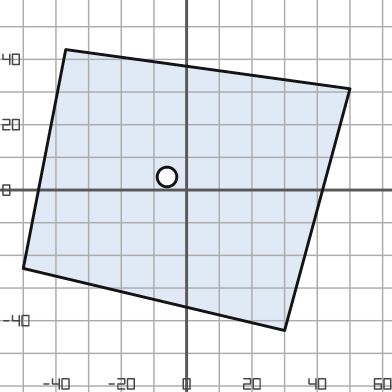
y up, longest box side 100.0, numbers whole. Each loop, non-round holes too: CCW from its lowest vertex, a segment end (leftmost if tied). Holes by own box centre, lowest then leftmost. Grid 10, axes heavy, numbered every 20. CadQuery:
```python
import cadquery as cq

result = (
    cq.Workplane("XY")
    .moveTo(30.0, -43.0)
    .lineTo(50.0, 31.0)
    .lineTo(-37.0, 43.0)
    .lineTo(-50.0, -24.0)
    .close()
    .moveTo(-6.0, 4.0)
    .circle(3.0)
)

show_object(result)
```